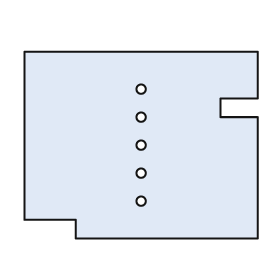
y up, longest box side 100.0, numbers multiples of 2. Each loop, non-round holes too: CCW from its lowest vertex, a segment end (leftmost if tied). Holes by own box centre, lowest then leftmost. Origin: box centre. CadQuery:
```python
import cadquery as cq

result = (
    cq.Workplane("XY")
    .moveTo(-28.0, -40.0)
    .lineTo(50.0, -40.0)
    .lineTo(50.0, 12.0)
    .lineTo(34.0, 12.0)
    .lineTo(34.0, 20.0)
    .lineTo(50.0, 20.0)
    .lineTo(50.0, 40.0)
    .lineTo(-50.0, 40.0)
    .lineTo(-50.0, -32.0)
    .lineTo(-28.0, -32.0)
    .close()
    .moveTo(0.0, -24.0)
    .circle(2.0)
    .moveTo(0.0, -12.0)
    .circle(2.0)
    .moveTo(0.0, 0.0)
    .circle(2.0)
    .moveTo(0.0, 12.0)
    .circle(2.0)
    .moveTo(0.0, 24.0)
    .circle(2.0)
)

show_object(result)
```